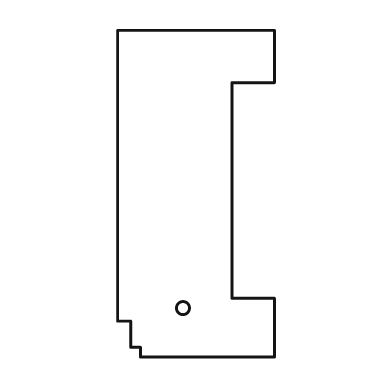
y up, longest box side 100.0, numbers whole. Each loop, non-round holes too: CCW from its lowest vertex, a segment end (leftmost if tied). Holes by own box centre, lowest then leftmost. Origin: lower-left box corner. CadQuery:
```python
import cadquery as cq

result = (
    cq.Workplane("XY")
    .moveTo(7.0, 0.0)
    .lineTo(48.0, 0.0)
    .lineTo(48.0, 18.0)
    .lineTo(35.0, 18.0)
    .lineTo(35.0, 84.0)
    .lineTo(48.0, 84.0)
    .lineTo(48.0, 100.0)
    .lineTo(0.0, 100.0)
    .lineTo(0.0, 11.0)
    .lineTo(4.0, 11.0)
    .lineTo(4.0, 3.0)
    .lineTo(7.0, 3.0)
    .close()
    .moveTo(20.0, 15.0)
    .circle(2.0)
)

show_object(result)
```